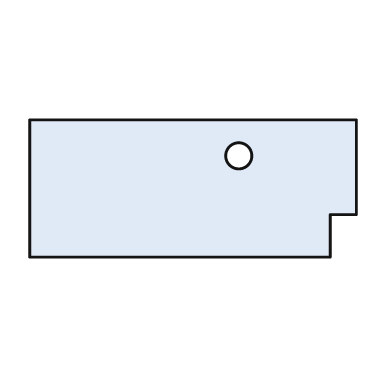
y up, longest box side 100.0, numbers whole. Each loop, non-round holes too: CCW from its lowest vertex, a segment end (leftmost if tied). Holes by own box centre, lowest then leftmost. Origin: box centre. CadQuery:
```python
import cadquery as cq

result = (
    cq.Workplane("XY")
    .moveTo(-50.0, -21.0)
    .lineTo(42.0, -21.0)
    .lineTo(42.0, -8.0)
    .lineTo(50.0, -8.0)
    .lineTo(50.0, 21.0)
    .lineTo(-50.0, 21.0)
    .close()
    .moveTo(14.0, 10.0)
    .circle(4.0)
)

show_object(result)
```